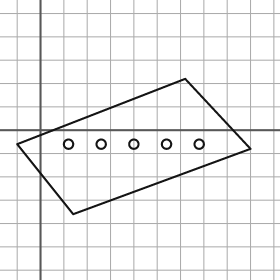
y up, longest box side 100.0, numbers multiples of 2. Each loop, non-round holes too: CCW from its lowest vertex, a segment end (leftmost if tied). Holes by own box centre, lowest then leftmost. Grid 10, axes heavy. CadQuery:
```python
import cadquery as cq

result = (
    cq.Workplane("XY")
    .moveTo(14.0, -36.0)
    .lineTo(90.0, -8.0)
    .lineTo(62.0, 22.0)
    .lineTo(-10.0, -6.0)
    .close()
    .moveTo(12.0, -6.0)
    .circle(2.0)
    .moveTo(26.0, -6.0)
    .circle(2.0)
    .moveTo(40.0, -6.0)
    .circle(2.0)
    .moveTo(54.0, -6.0)
    .circle(2.0)
    .moveTo(68.0, -6.0)
    .circle(2.0)
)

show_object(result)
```